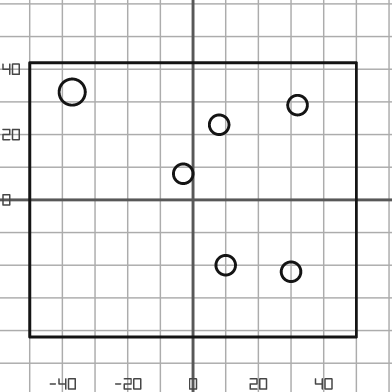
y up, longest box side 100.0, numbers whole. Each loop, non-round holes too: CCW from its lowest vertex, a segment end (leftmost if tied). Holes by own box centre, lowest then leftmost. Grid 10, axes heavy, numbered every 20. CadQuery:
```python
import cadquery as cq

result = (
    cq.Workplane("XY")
    .moveTo(-50.0, -42.0)
    .lineTo(50.0, -42.0)
    .lineTo(50.0, 42.0)
    .lineTo(-50.0, 42.0)
    .close()
    .moveTo(30.0, -22.0)
    .circle(3.0)
    .moveTo(10.0, -20.0)
    .circle(3.0)
    .moveTo(-3.0, 8.0)
    .circle(3.0)
    .moveTo(8.0, 23.0)
    .circle(3.0)
    .moveTo(32.0, 29.0)
    .circle(3.0)
    .moveTo(-37.0, 33.0)
    .circle(4.0)
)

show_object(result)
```